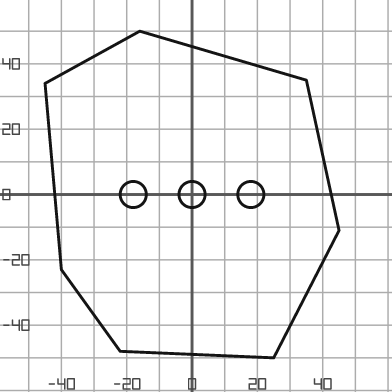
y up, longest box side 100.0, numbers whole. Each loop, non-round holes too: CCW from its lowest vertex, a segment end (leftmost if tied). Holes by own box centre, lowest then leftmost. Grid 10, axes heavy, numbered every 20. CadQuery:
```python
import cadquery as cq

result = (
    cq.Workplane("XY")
    .moveTo(25.0, -50.0)
    .lineTo(45.0, -11.0)
    .lineTo(35.0, 35.0)
    .lineTo(-16.0, 50.0)
    .lineTo(-45.0, 34.0)
    .lineTo(-40.0, -23.0)
    .lineTo(-22.0, -48.0)
    .close()
    .moveTo(-18.0, 0.0)
    .circle(4.0)
    .moveTo(0.0, 0.0)
    .circle(4.0)
    .moveTo(18.0, 0.0)
    .circle(4.0)
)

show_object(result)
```